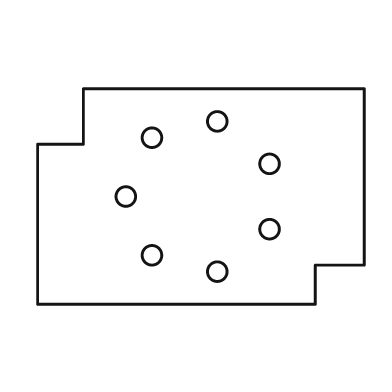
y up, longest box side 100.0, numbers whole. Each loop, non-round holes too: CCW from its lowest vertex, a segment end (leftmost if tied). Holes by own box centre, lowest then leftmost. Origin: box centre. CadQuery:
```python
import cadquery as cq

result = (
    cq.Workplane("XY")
    .moveTo(-50.0, -33.0)
    .lineTo(35.0, -33.0)
    .lineTo(35.0, -21.0)
    .lineTo(50.0, -21.0)
    .lineTo(50.0, 33.0)
    .lineTo(-36.0, 33.0)
    .lineTo(-36.0, 16.0)
    .lineTo(-50.0, 16.0)
    .close()
    .moveTo(5.0, -23.0)
    .circle(3.0)
    .moveTo(-15.0, -18.0)
    .circle(3.0)
    .moveTo(21.0, -10.0)
    .circle(3.0)
    .moveTo(-23.0, 0.0)
    .circle(3.0)
    .moveTo(21.0, 10.0)
    .circle(3.0)
    .moveTo(-15.0, 18.0)
    .circle(3.0)
    .moveTo(5.0, 23.0)
    .circle(3.0)
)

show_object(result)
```